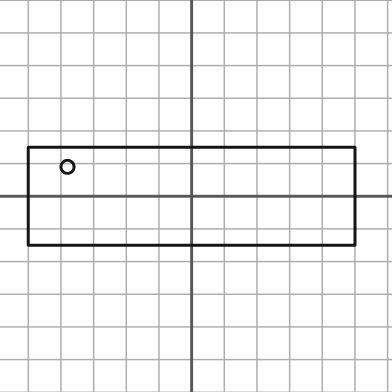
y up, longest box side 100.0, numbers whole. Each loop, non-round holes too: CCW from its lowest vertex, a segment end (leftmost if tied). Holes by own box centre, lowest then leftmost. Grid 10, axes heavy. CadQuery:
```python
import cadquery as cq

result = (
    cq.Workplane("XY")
    .moveTo(-50.0, -15.0)
    .lineTo(50.0, -15.0)
    .lineTo(50.0, 15.0)
    .lineTo(-50.0, 15.0)
    .close()
    .moveTo(-38.0, 9.0)
    .circle(2.0)
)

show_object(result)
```